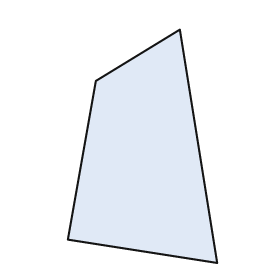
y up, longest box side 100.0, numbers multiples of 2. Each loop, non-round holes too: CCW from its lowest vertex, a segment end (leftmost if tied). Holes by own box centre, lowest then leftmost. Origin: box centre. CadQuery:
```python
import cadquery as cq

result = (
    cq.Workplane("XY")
    .moveTo(32.0, -50.0)
    .lineTo(16.0, 50.0)
    .lineTo(-20.0, 28.0)
    .lineTo(-32.0, -40.0)
    .close()
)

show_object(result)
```